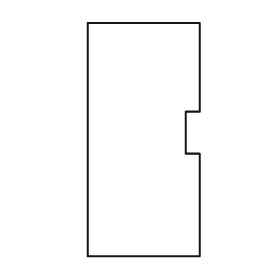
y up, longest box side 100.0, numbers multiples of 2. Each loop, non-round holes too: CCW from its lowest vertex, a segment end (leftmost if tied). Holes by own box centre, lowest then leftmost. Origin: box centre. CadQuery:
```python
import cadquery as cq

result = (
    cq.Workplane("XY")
    .moveTo(-24.0, -50.0)
    .lineTo(24.0, -50.0)
    .lineTo(24.0, -6.0)
    .lineTo(18.0, -6.0)
    .lineTo(18.0, 12.0)
    .lineTo(24.0, 12.0)
    .lineTo(24.0, 50.0)
    .lineTo(-24.0, 50.0)
    .close()
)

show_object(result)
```